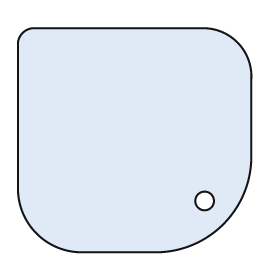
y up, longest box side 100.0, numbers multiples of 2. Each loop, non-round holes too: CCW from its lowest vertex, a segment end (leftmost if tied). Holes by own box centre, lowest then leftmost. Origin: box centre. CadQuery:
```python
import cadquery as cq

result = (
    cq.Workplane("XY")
    .moveTo(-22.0, -48.0)
    .lineTo(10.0, -48.0)
    .threePointArc((38.0, -36.0), (50.0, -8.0))
    .lineTo(50.0, 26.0)
    .threePointArc((44.0, 42.0), (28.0, 48.0))
    .lineTo(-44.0, 48.0)
    .threePointArc((-48.0, 46.0), (-50.0, 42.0))
    .lineTo(-50.0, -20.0)
    .threePointArc((-42.0, -40.0), (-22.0, -48.0))
    .close()
    .moveTo(30.0, -26.0)
    .circle(4.0)
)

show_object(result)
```